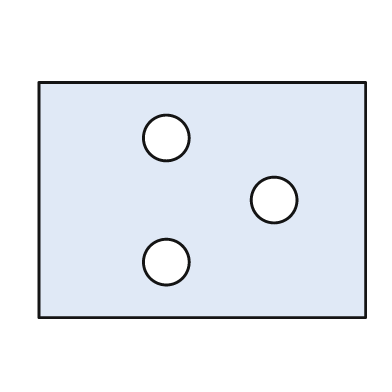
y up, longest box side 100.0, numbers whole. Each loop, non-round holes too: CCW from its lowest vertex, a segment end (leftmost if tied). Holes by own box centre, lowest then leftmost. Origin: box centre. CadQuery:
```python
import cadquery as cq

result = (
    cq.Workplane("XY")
    .moveTo(-50.0, -36.0)
    .lineTo(50.0, -36.0)
    .lineTo(50.0, 36.0)
    .lineTo(-50.0, 36.0)
    .close()
    .moveTo(-11.0, -19.0)
    .circle(7.0)
    .moveTo(22.0, 0.0)
    .circle(7.0)
    .moveTo(-11.0, 19.0)
    .circle(7.0)
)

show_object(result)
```